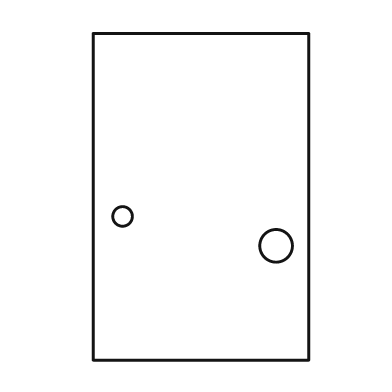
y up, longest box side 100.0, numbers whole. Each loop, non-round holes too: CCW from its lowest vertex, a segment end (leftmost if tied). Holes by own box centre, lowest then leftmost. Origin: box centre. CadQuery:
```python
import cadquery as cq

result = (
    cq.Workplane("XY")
    .moveTo(-33.0, -50.0)
    .lineTo(33.0, -50.0)
    .lineTo(33.0, 50.0)
    .lineTo(-33.0, 50.0)
    .close()
    .moveTo(23.0, -15.0)
    .circle(5.0)
    .moveTo(-24.0, -6.0)
    .circle(3.0)
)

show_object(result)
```